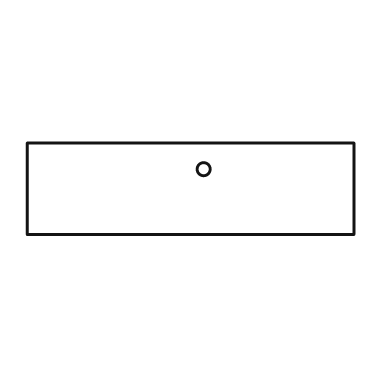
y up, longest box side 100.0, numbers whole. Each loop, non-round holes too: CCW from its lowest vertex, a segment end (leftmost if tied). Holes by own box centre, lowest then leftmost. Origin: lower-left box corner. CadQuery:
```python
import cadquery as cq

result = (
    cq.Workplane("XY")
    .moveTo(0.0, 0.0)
    .lineTo(100.0, 0.0)
    .lineTo(100.0, 28.0)
    .lineTo(0.0, 28.0)
    .close()
    .moveTo(54.0, 20.0)
    .circle(2.0)
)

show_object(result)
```